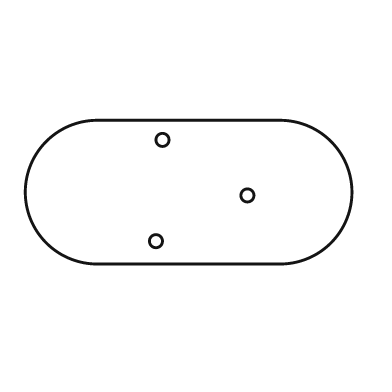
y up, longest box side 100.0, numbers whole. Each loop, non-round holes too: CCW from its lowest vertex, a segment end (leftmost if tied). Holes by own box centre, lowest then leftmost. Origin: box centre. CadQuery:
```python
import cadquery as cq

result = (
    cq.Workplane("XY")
    .moveTo(-28.0, -22.0)
    .lineTo(28.0, -22.0)
    .threePointArc((50.0, 0.0), (28.0, 22.0))
    .lineTo(-28.0, 22.0)
    .threePointArc((-50.0, 0.0), (-28.0, -22.0))
    .close()
    .moveTo(-10.0, -15.0)
    .circle(2.0)
    .moveTo(18.0, -1.0)
    .circle(2.0)
    .moveTo(-8.0, 16.0)
    .circle(2.0)
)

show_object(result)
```